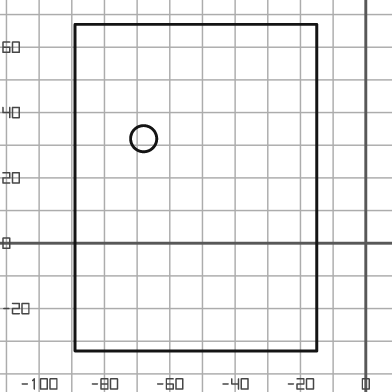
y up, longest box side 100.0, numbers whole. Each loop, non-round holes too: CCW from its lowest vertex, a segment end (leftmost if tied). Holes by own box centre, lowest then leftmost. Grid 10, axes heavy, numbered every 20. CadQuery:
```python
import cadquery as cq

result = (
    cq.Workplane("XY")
    .moveTo(-89.0, -33.0)
    .lineTo(-15.0, -33.0)
    .lineTo(-15.0, 67.0)
    .lineTo(-89.0, 67.0)
    .close()
    .moveTo(-68.0, 32.0)
    .circle(4.0)
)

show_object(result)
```